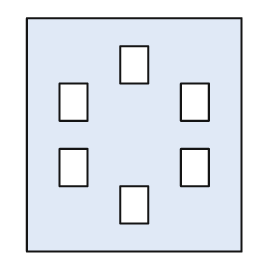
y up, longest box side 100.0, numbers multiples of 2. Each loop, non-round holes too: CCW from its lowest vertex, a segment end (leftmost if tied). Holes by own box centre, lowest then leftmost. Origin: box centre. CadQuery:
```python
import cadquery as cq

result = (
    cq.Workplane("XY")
    .moveTo(-46.0, -50.0)
    .lineTo(46.0, -50.0)
    .lineTo(46.0, 50.0)
    .lineTo(-46.0, 50.0)
    .close()
    .moveTo(-6.0, -38.0)
    .lineTo(6.0, -38.0)
    .lineTo(6.0, -22.0)
    .lineTo(-6.0, -22.0)
    .close()
    .moveTo(-32.0, -22.0)
    .lineTo(-20.0, -22.0)
    .lineTo(-20.0, -6.0)
    .lineTo(-32.0, -6.0)
    .close()
    .moveTo(20.0, -22.0)
    .lineTo(32.0, -22.0)
    .lineTo(32.0, -6.0)
    .lineTo(20.0, -6.0)
    .close()
    .moveTo(-32.0, 6.0)
    .lineTo(-20.0, 6.0)
    .lineTo(-20.0, 22.0)
    .lineTo(-32.0, 22.0)
    .close()
    .moveTo(20.0, 6.0)
    .lineTo(32.0, 6.0)
    .lineTo(32.0, 22.0)
    .lineTo(20.0, 22.0)
    .close()
    .moveTo(-6.0, 22.0)
    .lineTo(6.0, 22.0)
    .lineTo(6.0, 38.0)
    .lineTo(-6.0, 38.0)
    .close()
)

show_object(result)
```